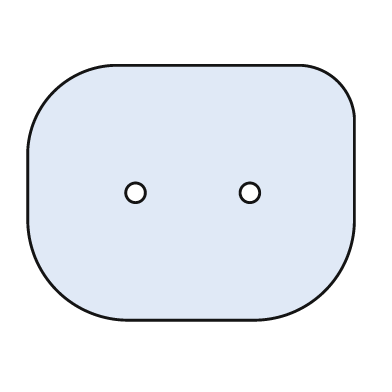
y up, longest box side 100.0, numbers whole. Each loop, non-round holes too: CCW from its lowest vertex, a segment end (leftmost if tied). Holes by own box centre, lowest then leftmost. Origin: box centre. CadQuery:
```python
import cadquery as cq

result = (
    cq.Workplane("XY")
    .moveTo(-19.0, -39.0)
    .lineTo(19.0, -39.0)
    .threePointArc((41.0, -30.0), (50.0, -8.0))
    .lineTo(50.0, 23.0)
    .threePointArc((45.0, 34.0), (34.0, 39.0))
    .lineTo(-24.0, 39.0)
    .threePointArc((-42.0, 31.0), (-50.0, 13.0))
    .lineTo(-50.0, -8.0)
    .threePointArc((-41.0, -30.0), (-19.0, -39.0))
    .close()
    .moveTo(-17.0, 0.0)
    .circle(3.0)
    .moveTo(18.0, 0.0)
    .circle(3.0)
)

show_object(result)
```